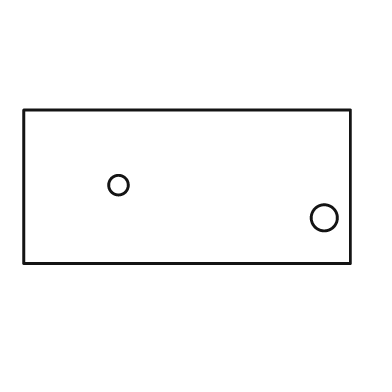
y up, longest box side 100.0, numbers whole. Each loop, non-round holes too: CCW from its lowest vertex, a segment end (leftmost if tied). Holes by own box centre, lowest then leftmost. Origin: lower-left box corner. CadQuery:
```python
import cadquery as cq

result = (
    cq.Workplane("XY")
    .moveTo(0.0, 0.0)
    .lineTo(100.0, 0.0)
    .lineTo(100.0, 47.0)
    .lineTo(0.0, 47.0)
    .close()
    .moveTo(92.0, 14.0)
    .circle(4.0)
    .moveTo(29.0, 24.0)
    .circle(3.0)
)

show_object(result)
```